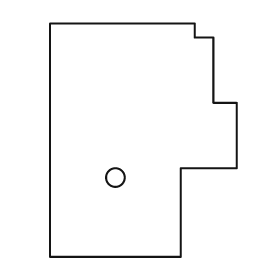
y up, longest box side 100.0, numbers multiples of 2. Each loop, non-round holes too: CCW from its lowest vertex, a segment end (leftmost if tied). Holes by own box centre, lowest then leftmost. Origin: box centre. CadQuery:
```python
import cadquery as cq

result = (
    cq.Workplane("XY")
    .moveTo(-40.0, -50.0)
    .lineTo(16.0, -50.0)
    .lineTo(16.0, -12.0)
    .lineTo(40.0, -12.0)
    .lineTo(40.0, 16.0)
    .lineTo(30.0, 16.0)
    .lineTo(30.0, 44.0)
    .lineTo(22.0, 44.0)
    .lineTo(22.0, 50.0)
    .lineTo(-40.0, 50.0)
    .close()
    .moveTo(-12.0, -16.0)
    .circle(4.0)
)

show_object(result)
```